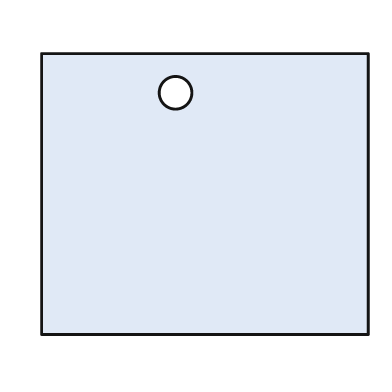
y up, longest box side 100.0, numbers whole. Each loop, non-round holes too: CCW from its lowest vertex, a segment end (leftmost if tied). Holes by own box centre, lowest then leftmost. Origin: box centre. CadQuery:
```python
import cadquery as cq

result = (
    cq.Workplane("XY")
    .moveTo(-50.0, -43.0)
    .lineTo(50.0, -43.0)
    .lineTo(50.0, 43.0)
    .lineTo(-50.0, 43.0)
    .close()
    .moveTo(-9.0, 31.0)
    .circle(5.0)
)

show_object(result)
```